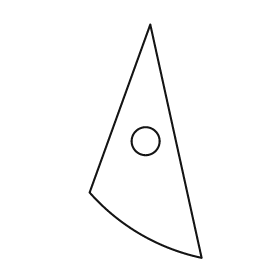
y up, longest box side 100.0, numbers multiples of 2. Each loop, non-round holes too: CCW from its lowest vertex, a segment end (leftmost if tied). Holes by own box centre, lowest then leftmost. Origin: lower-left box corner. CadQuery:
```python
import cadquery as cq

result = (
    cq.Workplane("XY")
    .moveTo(48.0, 0.0)
    .lineTo(26.0, 100.0)
    .lineTo(0.0, 28.0)
    .threePointArc((22.0, 10.0), (48.0, 0.0))
    .close()
    .moveTo(24.0, 50.0)
    .circle(6.0)
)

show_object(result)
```